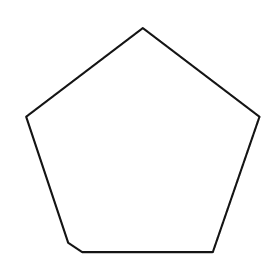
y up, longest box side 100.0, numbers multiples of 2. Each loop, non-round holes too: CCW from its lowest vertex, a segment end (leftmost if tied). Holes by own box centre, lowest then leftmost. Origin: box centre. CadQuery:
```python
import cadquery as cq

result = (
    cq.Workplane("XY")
    .moveTo(-26.0, -48.0)
    .lineTo(30.0, -48.0)
    .lineTo(50.0, 10.0)
    .lineTo(0.0, 48.0)
    .lineTo(-50.0, 10.0)
    .lineTo(-32.0, -44.0)
    .close()
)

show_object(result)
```